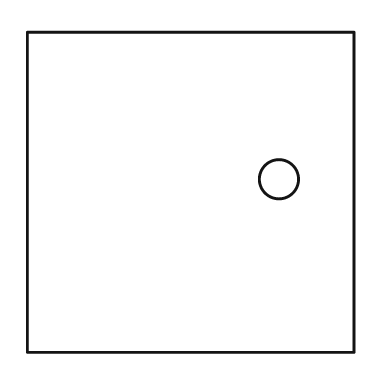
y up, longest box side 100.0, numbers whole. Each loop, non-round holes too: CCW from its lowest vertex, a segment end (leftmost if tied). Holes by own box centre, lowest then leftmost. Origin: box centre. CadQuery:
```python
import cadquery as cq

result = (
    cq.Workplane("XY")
    .moveTo(-50.0, -49.0)
    .lineTo(50.0, -49.0)
    .lineTo(50.0, 49.0)
    .lineTo(-50.0, 49.0)
    .close()
    .moveTo(27.0, 4.0)
    .circle(6.0)
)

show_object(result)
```